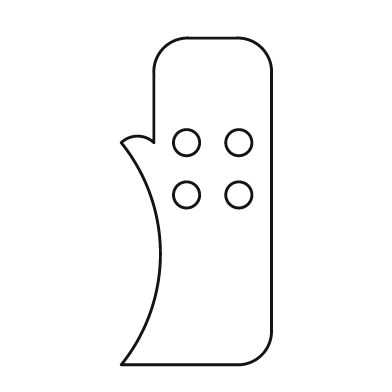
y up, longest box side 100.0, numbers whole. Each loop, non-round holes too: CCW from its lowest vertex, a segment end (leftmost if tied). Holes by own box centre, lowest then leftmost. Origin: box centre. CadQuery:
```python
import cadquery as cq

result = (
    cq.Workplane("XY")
    .moveTo(-23.0, -50.0)
    .lineTo(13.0, -50.0)
    .threePointArc((20.0, -47.0), (23.0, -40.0))
    .lineTo(23.0, 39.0)
    .threePointArc((20.0, 47.0), (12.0, 50.0))
    .lineTo(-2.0, 50.0)
    .threePointArc((-10.0, 47.0), (-13.0, 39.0))
    .lineTo(-13.0, 18.0)
    .threePointArc((-18.0, 20.0), (-23.0, 18.0))
    .threePointArc((-11.0, -16.0), (-23.0, -50.0))
    .close()
    .moveTo(-3.0, 2.0)
    .circle(4.0)
    .moveTo(13.0, 2.0)
    .circle(4.0)
    .moveTo(-3.0, 18.0)
    .circle(4.0)
    .moveTo(13.0, 18.0)
    .circle(4.0)
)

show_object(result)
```